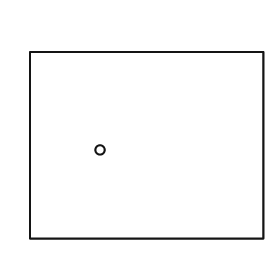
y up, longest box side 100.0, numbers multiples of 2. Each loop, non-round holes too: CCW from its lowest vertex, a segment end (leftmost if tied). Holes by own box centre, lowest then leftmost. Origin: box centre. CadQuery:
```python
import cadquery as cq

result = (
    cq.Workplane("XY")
    .moveTo(-50.0, -40.0)
    .lineTo(50.0, -40.0)
    .lineTo(50.0, 40.0)
    .lineTo(-50.0, 40.0)
    .close()
    .moveTo(-20.0, -2.0)
    .circle(2.0)
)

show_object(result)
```